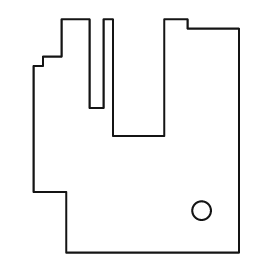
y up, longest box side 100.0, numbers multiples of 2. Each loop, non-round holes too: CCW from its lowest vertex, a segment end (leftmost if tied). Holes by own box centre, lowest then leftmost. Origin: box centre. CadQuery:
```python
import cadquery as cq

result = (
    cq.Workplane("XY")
    .moveTo(-30.0, -50.0)
    .lineTo(44.0, -50.0)
    .lineTo(44.0, 46.0)
    .lineTo(22.0, 46.0)
    .lineTo(22.0, 50.0)
    .lineTo(12.0, 50.0)
    .lineTo(12.0, 0.0)
    .lineTo(-10.0, 0.0)
    .lineTo(-10.0, 50.0)
    .lineTo(-14.0, 50.0)
    .lineTo(-14.0, 12.0)
    .lineTo(-20.0, 12.0)
    .lineTo(-20.0, 50.0)
    .lineTo(-32.0, 50.0)
    .lineTo(-32.0, 34.0)
    .lineTo(-40.0, 34.0)
    .lineTo(-40.0, 30.0)
    .lineTo(-44.0, 30.0)
    .lineTo(-44.0, -24.0)
    .lineTo(-30.0, -24.0)
    .close()
    .moveTo(28.0, -32.0)
    .circle(4.0)
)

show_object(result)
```